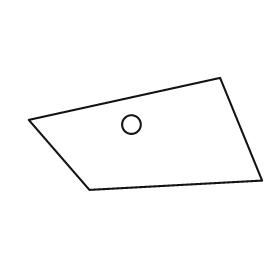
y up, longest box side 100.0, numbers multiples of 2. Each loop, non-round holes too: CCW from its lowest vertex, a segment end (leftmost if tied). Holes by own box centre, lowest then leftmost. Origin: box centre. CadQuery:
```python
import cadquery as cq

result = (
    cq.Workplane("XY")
    .moveTo(-24.0, -24.0)
    .lineTo(50.0, -20.0)
    .lineTo(32.0, 24.0)
    .lineTo(-50.0, 6.0)
    .close()
    .moveTo(-6.0, 4.0)
    .circle(4.0)
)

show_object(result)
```